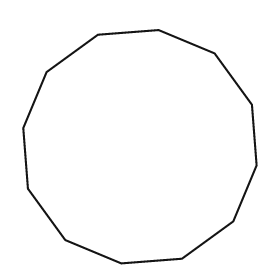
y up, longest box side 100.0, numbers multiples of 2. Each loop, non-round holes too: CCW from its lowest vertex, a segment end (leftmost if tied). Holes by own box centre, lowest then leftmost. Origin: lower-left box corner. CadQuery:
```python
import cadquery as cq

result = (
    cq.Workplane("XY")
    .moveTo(42.0, 0.0)
    .lineTo(68.0, 2.0)
    .lineTo(90.0, 18.0)
    .lineTo(100.0, 42.0)
    .lineTo(98.0, 68.0)
    .lineTo(82.0, 90.0)
    .lineTo(58.0, 100.0)
    .lineTo(32.0, 98.0)
    .lineTo(10.0, 82.0)
    .lineTo(0.0, 58.0)
    .lineTo(2.0, 32.0)
    .lineTo(18.0, 10.0)
    .close()
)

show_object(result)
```